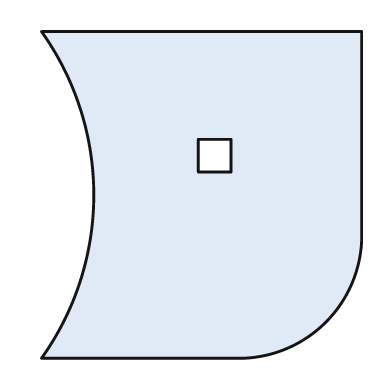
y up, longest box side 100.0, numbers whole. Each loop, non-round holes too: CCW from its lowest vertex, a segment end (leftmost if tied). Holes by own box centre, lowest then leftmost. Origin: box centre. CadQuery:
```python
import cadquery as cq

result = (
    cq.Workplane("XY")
    .moveTo(-49.0, -50.0)
    .lineTo(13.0, -50.0)
    .threePointArc((38.0, -39.0), (49.0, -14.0))
    .lineTo(49.0, 50.0)
    .lineTo(-49.0, 50.0)
    .threePointArc((-33.0, 0.0), (-49.0, -50.0))
    .close()
    .moveTo(-1.0, 7.0)
    .lineTo(9.0, 7.0)
    .lineTo(9.0, 17.0)
    .lineTo(-1.0, 17.0)
    .close()
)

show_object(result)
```